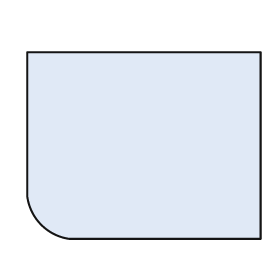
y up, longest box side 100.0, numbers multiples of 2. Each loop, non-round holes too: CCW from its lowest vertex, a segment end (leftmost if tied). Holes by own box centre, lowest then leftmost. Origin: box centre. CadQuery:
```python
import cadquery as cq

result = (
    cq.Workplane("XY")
    .moveTo(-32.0, -40.0)
    .lineTo(50.0, -40.0)
    .lineTo(50.0, 40.0)
    .lineTo(-50.0, 40.0)
    .lineTo(-50.0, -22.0)
    .threePointArc((-44.0, -34.0), (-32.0, -40.0))
    .close()
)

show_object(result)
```